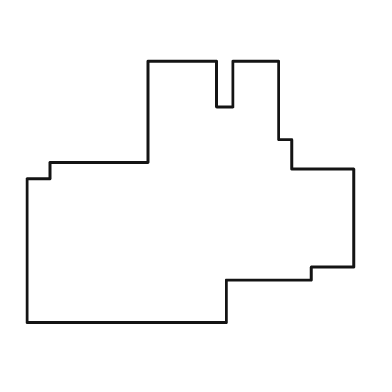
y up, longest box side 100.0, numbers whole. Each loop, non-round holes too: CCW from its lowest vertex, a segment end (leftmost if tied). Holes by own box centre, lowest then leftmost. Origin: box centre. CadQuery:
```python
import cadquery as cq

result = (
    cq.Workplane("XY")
    .moveTo(-50.0, -40.0)
    .lineTo(11.0, -40.0)
    .lineTo(11.0, -27.0)
    .lineTo(37.0, -27.0)
    .lineTo(37.0, -23.0)
    .lineTo(50.0, -23.0)
    .lineTo(50.0, 7.0)
    .lineTo(31.0, 7.0)
    .lineTo(31.0, 16.0)
    .lineTo(27.0, 16.0)
    .lineTo(27.0, 40.0)
    .lineTo(13.0, 40.0)
    .lineTo(13.0, 26.0)
    .lineTo(8.0, 26.0)
    .lineTo(8.0, 40.0)
    .lineTo(-13.0, 40.0)
    .lineTo(-13.0, 9.0)
    .lineTo(-43.0, 9.0)
    .lineTo(-43.0, 4.0)
    .lineTo(-50.0, 4.0)
    .close()
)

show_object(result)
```